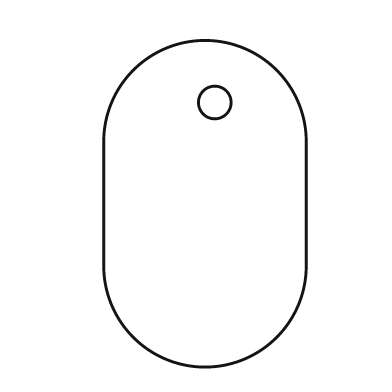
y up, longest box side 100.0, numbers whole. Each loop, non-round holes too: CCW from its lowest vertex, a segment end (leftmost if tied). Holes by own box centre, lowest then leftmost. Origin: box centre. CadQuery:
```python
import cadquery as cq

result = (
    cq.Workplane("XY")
    .moveTo(-31.0, -19.0)
    .threePointArc((0.0, -50.0), (31.0, -19.0))
    .lineTo(31.0, 19.0)
    .threePointArc((0.0, 50.0), (-31.0, 19.0))
    .close()
    .moveTo(3.0, 31.0)
    .circle(5.0)
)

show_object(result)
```